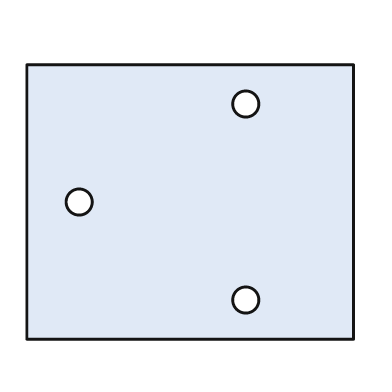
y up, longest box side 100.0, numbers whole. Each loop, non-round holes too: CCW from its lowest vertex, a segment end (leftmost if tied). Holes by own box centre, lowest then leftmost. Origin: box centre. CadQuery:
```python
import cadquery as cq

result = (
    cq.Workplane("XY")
    .moveTo(-50.0, -42.0)
    .lineTo(50.0, -42.0)
    .lineTo(50.0, 42.0)
    .lineTo(-50.0, 42.0)
    .close()
    .moveTo(17.0, -30.0)
    .circle(4.0)
    .moveTo(-34.0, 0.0)
    .circle(4.0)
    .moveTo(17.0, 30.0)
    .circle(4.0)
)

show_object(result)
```